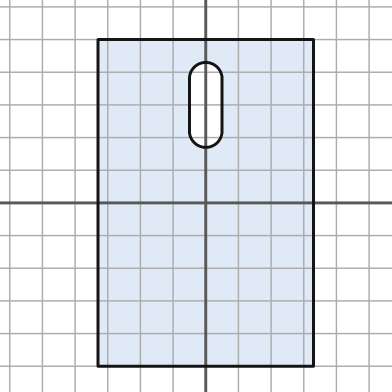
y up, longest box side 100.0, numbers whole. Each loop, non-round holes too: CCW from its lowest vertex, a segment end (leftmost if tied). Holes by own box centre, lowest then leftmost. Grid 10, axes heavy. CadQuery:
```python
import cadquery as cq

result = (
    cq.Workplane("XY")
    .moveTo(-33.0, -50.0)
    .lineTo(33.0, -50.0)
    .lineTo(33.0, 50.0)
    .lineTo(-33.0, 50.0)
    .close()
    .moveTo(-5.0, 22.0)
    .threePointArc((0.0, 17.0), (5.0, 22.0))
    .lineTo(5.0, 38.0)
    .threePointArc((0.0, 43.0), (-5.0, 38.0))
    .close()
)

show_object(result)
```